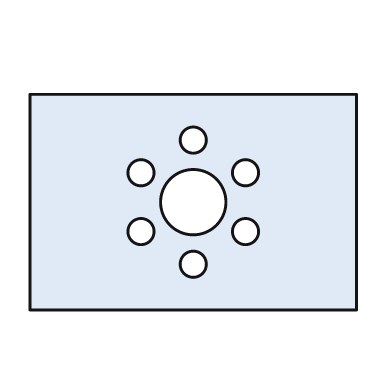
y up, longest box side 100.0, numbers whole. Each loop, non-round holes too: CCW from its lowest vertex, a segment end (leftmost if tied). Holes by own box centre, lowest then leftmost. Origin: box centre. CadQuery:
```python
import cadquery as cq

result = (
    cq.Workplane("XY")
    .moveTo(-50.0, -33.0)
    .lineTo(50.0, -33.0)
    .lineTo(50.0, 33.0)
    .lineTo(-50.0, 33.0)
    .close()
    .moveTo(0.0, -19.0)
    .circle(4.0)
    .moveTo(-16.0, -9.0)
    .circle(4.0)
    .moveTo(16.0, -9.0)
    .circle(4.0)
    .moveTo(0.0, 0.0)
    .circle(10.0)
    .moveTo(-16.0, 9.0)
    .circle(4.0)
    .moveTo(16.0, 9.0)
    .circle(4.0)
    .moveTo(0.0, 19.0)
    .circle(4.0)
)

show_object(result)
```